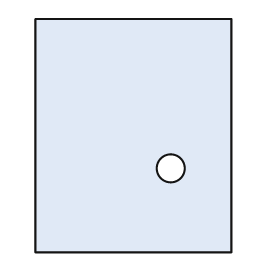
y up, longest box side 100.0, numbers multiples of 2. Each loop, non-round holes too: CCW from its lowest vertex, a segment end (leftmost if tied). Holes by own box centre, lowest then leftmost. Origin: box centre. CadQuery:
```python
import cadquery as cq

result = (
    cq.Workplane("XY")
    .moveTo(-42.0, -50.0)
    .lineTo(42.0, -50.0)
    .lineTo(42.0, 50.0)
    .lineTo(-42.0, 50.0)
    .close()
    .moveTo(16.0, -14.0)
    .circle(6.0)
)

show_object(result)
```